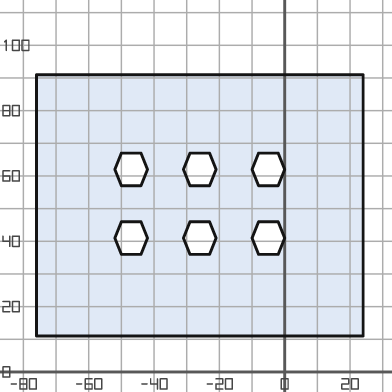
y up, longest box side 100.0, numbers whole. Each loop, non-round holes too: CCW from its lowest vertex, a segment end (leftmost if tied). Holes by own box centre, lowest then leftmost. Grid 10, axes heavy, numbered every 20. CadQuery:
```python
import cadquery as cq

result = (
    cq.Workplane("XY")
    .moveTo(-76.0, 11.0)
    .lineTo(24.0, 11.0)
    .lineTo(24.0, 91.0)
    .lineTo(-76.0, 91.0)
    .close()
    .moveTo(-50.0, 36.0)
    .lineTo(-44.0, 36.0)
    .lineTo(-42.0, 41.0)
    .lineTo(-44.0, 46.0)
    .lineTo(-50.0, 46.0)
    .lineTo(-52.0, 41.0)
    .close()
    .moveTo(-29.0, 36.0)
    .lineTo(-23.0, 36.0)
    .lineTo(-21.0, 41.0)
    .lineTo(-23.0, 46.0)
    .lineTo(-29.0, 46.0)
    .lineTo(-31.0, 41.0)
    .close()
    .moveTo(-8.0, 36.0)
    .lineTo(-2.0, 36.0)
    .lineTo(0.0, 41.0)
    .lineTo(-2.0, 46.0)
    .lineTo(-8.0, 46.0)
    .lineTo(-10.0, 41.0)
    .close()
    .moveTo(-50.0, 57.0)
    .lineTo(-44.0, 57.0)
    .lineTo(-42.0, 62.0)
    .lineTo(-44.0, 67.0)
    .lineTo(-50.0, 67.0)
    .lineTo(-52.0, 62.0)
    .close()
    .moveTo(-29.0, 57.0)
    .lineTo(-23.0, 57.0)
    .lineTo(-21.0, 62.0)
    .lineTo(-23.0, 67.0)
    .lineTo(-29.0, 67.0)
    .lineTo(-31.0, 62.0)
    .close()
    .moveTo(-8.0, 57.0)
    .lineTo(-2.0, 57.0)
    .lineTo(0.0, 62.0)
    .lineTo(-2.0, 67.0)
    .lineTo(-8.0, 67.0)
    .lineTo(-10.0, 62.0)
    .close()
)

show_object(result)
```